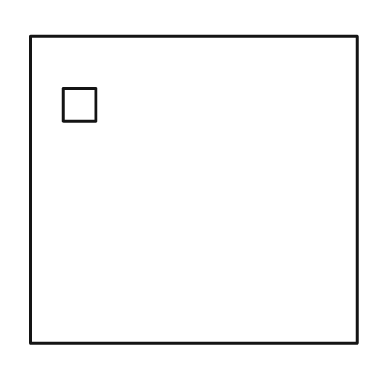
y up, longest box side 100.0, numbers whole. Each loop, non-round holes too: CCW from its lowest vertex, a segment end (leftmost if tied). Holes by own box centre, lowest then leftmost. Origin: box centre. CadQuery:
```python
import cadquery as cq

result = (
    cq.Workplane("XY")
    .moveTo(-50.0, -47.0)
    .lineTo(50.0, -47.0)
    .lineTo(50.0, 47.0)
    .lineTo(-50.0, 47.0)
    .close()
    .moveTo(-40.0, 21.0)
    .lineTo(-30.0, 21.0)
    .lineTo(-30.0, 31.0)
    .lineTo(-40.0, 31.0)
    .close()
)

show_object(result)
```